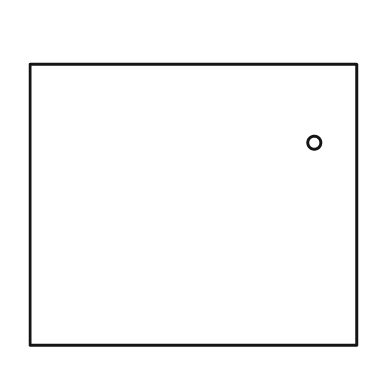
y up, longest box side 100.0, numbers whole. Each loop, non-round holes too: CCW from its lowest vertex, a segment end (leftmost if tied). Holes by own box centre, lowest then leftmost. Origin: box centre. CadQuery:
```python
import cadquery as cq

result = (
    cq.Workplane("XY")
    .moveTo(-50.0, -43.0)
    .lineTo(50.0, -43.0)
    .lineTo(50.0, 43.0)
    .lineTo(-50.0, 43.0)
    .close()
    .moveTo(37.0, 19.0)
    .circle(2.0)
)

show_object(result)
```